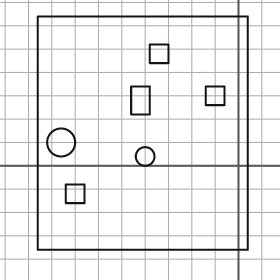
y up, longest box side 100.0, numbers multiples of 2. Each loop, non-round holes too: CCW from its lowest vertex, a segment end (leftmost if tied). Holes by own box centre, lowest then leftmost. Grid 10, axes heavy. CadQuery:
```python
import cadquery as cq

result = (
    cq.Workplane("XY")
    .moveTo(-86.0, -36.0)
    .lineTo(4.0, -36.0)
    .lineTo(4.0, 64.0)
    .lineTo(-86.0, 64.0)
    .close()
    .moveTo(-74.0, -16.0)
    .lineTo(-66.0, -16.0)
    .lineTo(-66.0, -8.0)
    .lineTo(-74.0, -8.0)
    .close()
    .moveTo(-40.0, 4.0)
    .circle(4.0)
    .moveTo(-76.0, 10.0)
    .circle(6.0)
    .moveTo(-46.0, 22.0)
    .lineTo(-38.0, 22.0)
    .lineTo(-38.0, 34.0)
    .lineTo(-46.0, 34.0)
    .close()
    .moveTo(-14.0, 26.0)
    .lineTo(-6.0, 26.0)
    .lineTo(-6.0, 34.0)
    .lineTo(-14.0, 34.0)
    .close()
    .moveTo(-38.0, 44.0)
    .lineTo(-30.0, 44.0)
    .lineTo(-30.0, 52.0)
    .lineTo(-38.0, 52.0)
    .close()
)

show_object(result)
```